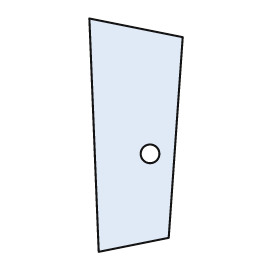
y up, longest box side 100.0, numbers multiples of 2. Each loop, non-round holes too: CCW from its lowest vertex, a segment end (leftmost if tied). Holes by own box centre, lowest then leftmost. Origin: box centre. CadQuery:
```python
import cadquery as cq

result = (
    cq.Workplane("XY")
    .moveTo(-16.0, -50.0)
    .lineTo(14.0, -44.0)
    .lineTo(20.0, 42.0)
    .lineTo(-20.0, 50.0)
    .close()
    .moveTo(6.0, -8.0)
    .circle(4.0)
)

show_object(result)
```